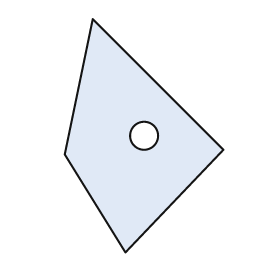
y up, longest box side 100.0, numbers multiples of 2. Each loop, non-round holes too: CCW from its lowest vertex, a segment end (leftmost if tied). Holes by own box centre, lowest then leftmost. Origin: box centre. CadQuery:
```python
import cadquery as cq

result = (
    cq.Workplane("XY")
    .moveTo(-8.0, -50.0)
    .lineTo(34.0, -6.0)
    .lineTo(-22.0, 50.0)
    .lineTo(-34.0, -8.0)
    .close()
    .moveTo(0.0, 0.0)
    .circle(6.0)
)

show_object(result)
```